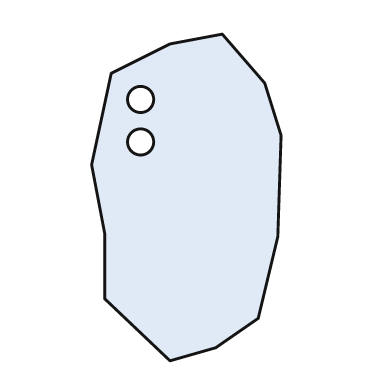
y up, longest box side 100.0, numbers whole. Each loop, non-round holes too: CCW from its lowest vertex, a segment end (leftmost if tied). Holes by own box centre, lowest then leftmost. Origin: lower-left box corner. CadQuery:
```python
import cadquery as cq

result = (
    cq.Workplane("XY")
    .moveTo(24.0, 0.0)
    .lineTo(38.0, 4.0)
    .lineTo(51.0, 13.0)
    .lineTo(57.0, 38.0)
    .lineTo(58.0, 69.0)
    .lineTo(53.0, 85.0)
    .lineTo(40.0, 100.0)
    .lineTo(24.0, 97.0)
    .lineTo(6.0, 88.0)
    .lineTo(0.0, 60.0)
    .lineTo(4.0, 39.0)
    .lineTo(4.0, 19.0)
    .close()
    .moveTo(15.0, 67.0)
    .circle(4.0)
    .moveTo(15.0, 80.0)
    .circle(4.0)
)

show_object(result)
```